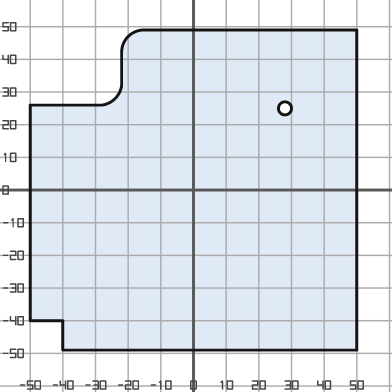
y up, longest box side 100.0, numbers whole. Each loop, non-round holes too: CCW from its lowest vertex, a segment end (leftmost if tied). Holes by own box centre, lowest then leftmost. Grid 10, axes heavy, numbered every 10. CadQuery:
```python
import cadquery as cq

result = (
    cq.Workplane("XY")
    .moveTo(-40.0, -49.0)
    .lineTo(50.0, -49.0)
    .lineTo(50.0, 49.0)
    .lineTo(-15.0, 49.0)
    .threePointArc((-20.0, 47.0), (-22.0, 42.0))
    .lineTo(-22.0, 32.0)
    .threePointArc((-24.0, 28.0), (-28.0, 26.0))
    .lineTo(-50.0, 26.0)
    .lineTo(-50.0, -40.0)
    .lineTo(-40.0, -40.0)
    .close()
    .moveTo(28.0, 25.0)
    .circle(2.0)
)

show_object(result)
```